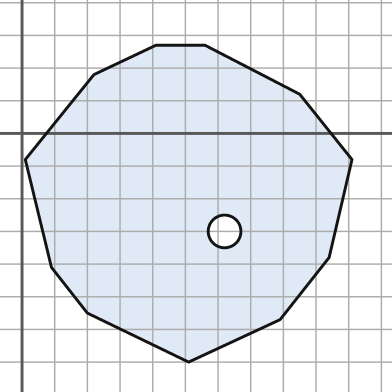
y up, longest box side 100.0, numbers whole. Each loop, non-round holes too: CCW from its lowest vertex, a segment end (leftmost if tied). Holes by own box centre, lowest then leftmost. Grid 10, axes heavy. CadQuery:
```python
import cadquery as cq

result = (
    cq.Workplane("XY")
    .moveTo(51.0, -70.0)
    .lineTo(79.0, -57.0)
    .lineTo(94.0, -38.0)
    .lineTo(101.0, -8.0)
    .lineTo(85.0, 12.0)
    .lineTo(56.0, 27.0)
    .lineTo(41.0, 27.0)
    .lineTo(22.0, 18.0)
    .lineTo(1.0, -8.0)
    .lineTo(9.0, -41.0)
    .lineTo(20.0, -55.0)
    .close()
    .moveTo(62.0, -30.0)
    .circle(5.0)
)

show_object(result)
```